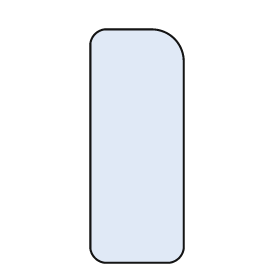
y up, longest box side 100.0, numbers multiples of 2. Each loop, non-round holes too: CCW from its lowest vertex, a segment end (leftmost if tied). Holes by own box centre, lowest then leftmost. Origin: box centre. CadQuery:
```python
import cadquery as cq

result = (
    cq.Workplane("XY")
    .moveTo(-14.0, -50.0)
    .lineTo(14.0, -50.0)
    .threePointArc((18.0, -48.0), (20.0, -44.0))
    .lineTo(20.0, 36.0)
    .threePointArc((16.0, 46.0), (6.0, 50.0))
    .lineTo(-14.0, 50.0)
    .threePointArc((-18.0, 48.0), (-20.0, 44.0))
    .lineTo(-20.0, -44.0)
    .threePointArc((-18.0, -48.0), (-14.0, -50.0))
    .close()
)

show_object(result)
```